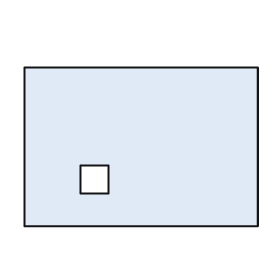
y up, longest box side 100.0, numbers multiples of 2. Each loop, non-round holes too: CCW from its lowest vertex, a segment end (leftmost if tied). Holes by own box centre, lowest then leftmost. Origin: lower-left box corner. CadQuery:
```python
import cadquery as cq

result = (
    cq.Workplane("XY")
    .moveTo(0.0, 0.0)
    .lineTo(100.0, 0.0)
    .lineTo(100.0, 68.0)
    .lineTo(0.0, 68.0)
    .close()
    .moveTo(24.0, 14.0)
    .lineTo(36.0, 14.0)
    .lineTo(36.0, 26.0)
    .lineTo(24.0, 26.0)
    .close()
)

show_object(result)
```